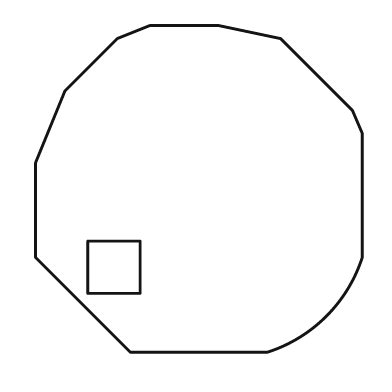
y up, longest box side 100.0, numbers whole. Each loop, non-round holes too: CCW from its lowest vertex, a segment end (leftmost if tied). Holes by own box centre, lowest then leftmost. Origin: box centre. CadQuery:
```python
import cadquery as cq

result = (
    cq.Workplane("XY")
    .moveTo(-21.0, -50.0)
    .lineTo(21.0, -50.0)
    .threePointArc((39.0, -39.0), (50.0, -21.0))
    .lineTo(50.0, 17.0)
    .lineTo(47.0, 24.0)
    .lineTo(25.0, 46.0)
    .lineTo(6.0, 50.0)
    .lineTo(-15.0, 50.0)
    .lineTo(-25.0, 46.0)
    .lineTo(-41.0, 30.0)
    .lineTo(-50.0, 8.0)
    .lineTo(-50.0, -21.0)
    .close()
    .moveTo(-34.0, -32.0)
    .lineTo(-18.0, -32.0)
    .lineTo(-18.0, -16.0)
    .lineTo(-34.0, -16.0)
    .close()
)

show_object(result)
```